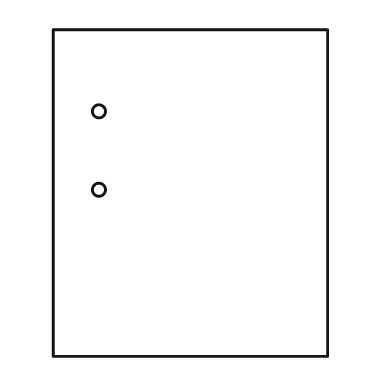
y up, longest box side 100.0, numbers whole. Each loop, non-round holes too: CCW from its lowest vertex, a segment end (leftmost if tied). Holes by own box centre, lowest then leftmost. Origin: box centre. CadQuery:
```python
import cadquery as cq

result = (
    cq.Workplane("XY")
    .moveTo(-42.0, -50.0)
    .lineTo(42.0, -50.0)
    .lineTo(42.0, 50.0)
    .lineTo(-42.0, 50.0)
    .close()
    .moveTo(-28.0, 1.0)
    .circle(2.0)
    .moveTo(-28.0, 25.0)
    .circle(2.0)
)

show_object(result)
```